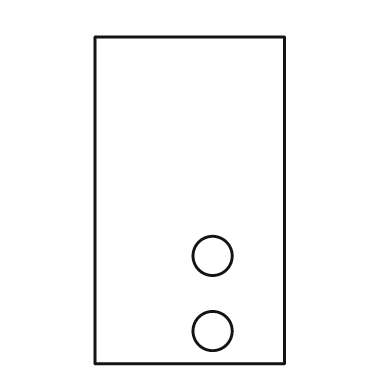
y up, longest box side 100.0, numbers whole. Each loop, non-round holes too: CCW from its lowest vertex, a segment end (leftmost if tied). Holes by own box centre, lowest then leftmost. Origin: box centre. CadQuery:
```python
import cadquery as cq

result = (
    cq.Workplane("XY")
    .moveTo(-29.0, -50.0)
    .lineTo(29.0, -50.0)
    .lineTo(29.0, 50.0)
    .lineTo(-29.0, 50.0)
    .close()
    .moveTo(7.0, -40.0)
    .circle(6.0)
    .moveTo(7.0, -17.0)
    .circle(6.0)
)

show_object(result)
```